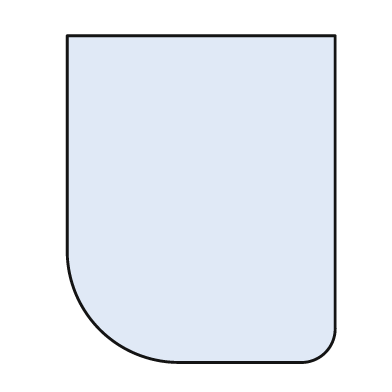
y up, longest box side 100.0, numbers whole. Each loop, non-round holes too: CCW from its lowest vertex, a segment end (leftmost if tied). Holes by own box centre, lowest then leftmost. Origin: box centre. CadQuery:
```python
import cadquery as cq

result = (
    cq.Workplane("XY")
    .moveTo(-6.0, -50.0)
    .lineTo(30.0, -50.0)
    .threePointArc((38.0, -47.0), (41.0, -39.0))
    .lineTo(41.0, 50.0)
    .lineTo(-41.0, 50.0)
    .lineTo(-41.0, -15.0)
    .threePointArc((-31.0, -40.0), (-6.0, -50.0))
    .close()
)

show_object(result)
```